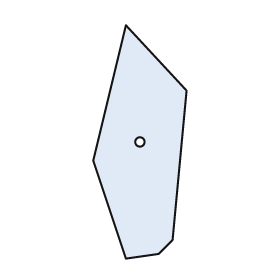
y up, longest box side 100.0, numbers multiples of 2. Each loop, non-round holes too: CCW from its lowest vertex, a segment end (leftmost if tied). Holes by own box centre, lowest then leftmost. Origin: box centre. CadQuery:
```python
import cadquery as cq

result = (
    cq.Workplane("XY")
    .moveTo(-6.0, -50.0)
    .lineTo(8.0, -48.0)
    .lineTo(14.0, -42.0)
    .lineTo(20.0, 22.0)
    .lineTo(-6.0, 50.0)
    .lineTo(-20.0, -8.0)
    .close()
    .moveTo(0.0, 0.0)
    .circle(2.0)
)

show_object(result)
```